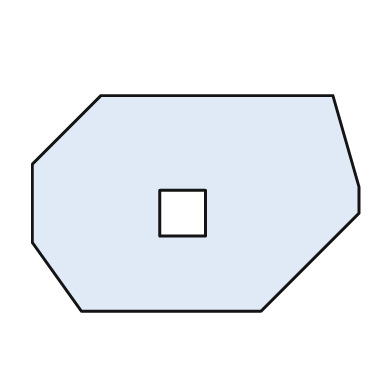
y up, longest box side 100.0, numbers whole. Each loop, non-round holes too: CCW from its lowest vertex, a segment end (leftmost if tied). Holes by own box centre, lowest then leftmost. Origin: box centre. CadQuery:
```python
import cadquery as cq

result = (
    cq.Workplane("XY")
    .moveTo(-35.0, -33.0)
    .lineTo(20.0, -33.0)
    .lineTo(50.0, -3.0)
    .lineTo(50.0, 5.0)
    .lineTo(42.0, 33.0)
    .lineTo(-29.0, 33.0)
    .lineTo(-50.0, 12.0)
    .lineTo(-50.0, -12.0)
    .close()
    .moveTo(-11.0, -10.0)
    .lineTo(3.0, -10.0)
    .lineTo(3.0, 4.0)
    .lineTo(-11.0, 4.0)
    .close()
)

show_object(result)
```